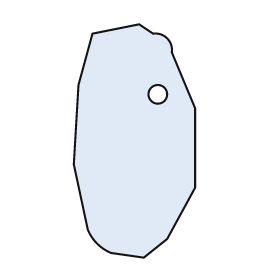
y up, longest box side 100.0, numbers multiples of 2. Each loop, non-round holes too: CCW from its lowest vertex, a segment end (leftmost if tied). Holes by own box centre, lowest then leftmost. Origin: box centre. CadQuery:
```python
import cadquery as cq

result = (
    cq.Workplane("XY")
    .moveTo(4.0, -50.0)
    .lineTo(14.0, -42.0)
    .lineTo(26.0, -20.0)
    .lineTo(26.0, 14.0)
    .lineTo(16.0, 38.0)
    .threePointArc((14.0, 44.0), (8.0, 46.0))
    .lineTo(2.0, 50.0)
    .lineTo(-18.0, 46.0)
    .lineTo(-24.0, 24.0)
    .lineTo(-26.0, -10.0)
    .lineTo(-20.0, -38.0)
    .threePointArc((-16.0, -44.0), (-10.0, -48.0))
    .close()
    .moveTo(10.0, 20.0)
    .circle(4.0)
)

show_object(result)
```